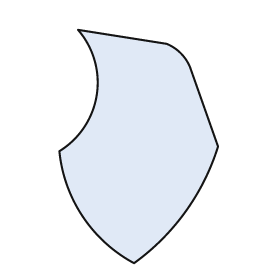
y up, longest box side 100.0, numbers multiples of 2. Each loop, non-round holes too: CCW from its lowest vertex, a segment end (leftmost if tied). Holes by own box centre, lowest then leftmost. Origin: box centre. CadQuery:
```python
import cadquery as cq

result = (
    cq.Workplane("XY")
    .moveTo(-2.0, -50.0)
    .threePointArc((20.0, -28.0), (34.0, 0.0))
    .lineTo(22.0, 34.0)
    .threePointArc((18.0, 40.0), (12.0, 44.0))
    .lineTo(-26.0, 50.0)
    .threePointArc((-18.0, 22.0), (-34.0, -2.0))
    .threePointArc((-24.0, -30.0), (-2.0, -50.0))
    .close()
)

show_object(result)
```